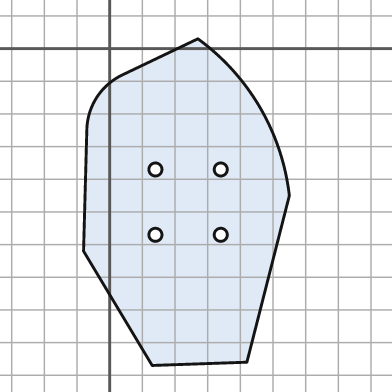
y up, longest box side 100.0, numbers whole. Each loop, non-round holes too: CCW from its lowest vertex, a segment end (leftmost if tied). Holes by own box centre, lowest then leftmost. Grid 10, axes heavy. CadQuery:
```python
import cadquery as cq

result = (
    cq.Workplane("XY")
    .moveTo(13.0, -97.0)
    .lineTo(42.0, -96.0)
    .lineTo(55.0, -45.0)
    .threePointArc((46.0, -18.0), (27.0, 3.0))
    .lineTo(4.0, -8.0)
    .threePointArc((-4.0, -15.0), (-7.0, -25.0))
    .lineTo(-8.0, -62.0)
    .close()
    .moveTo(14.0, -57.0)
    .circle(2.0)
    .moveTo(34.0, -57.0)
    .circle(2.0)
    .moveTo(14.0, -37.0)
    .circle(2.0)
    .moveTo(34.0, -37.0)
    .circle(2.0)
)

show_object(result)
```